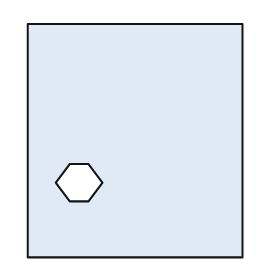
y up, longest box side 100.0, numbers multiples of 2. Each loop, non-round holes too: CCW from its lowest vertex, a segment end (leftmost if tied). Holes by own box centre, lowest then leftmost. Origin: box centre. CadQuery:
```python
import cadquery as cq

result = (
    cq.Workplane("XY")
    .moveTo(-46.0, -50.0)
    .lineTo(46.0, -50.0)
    .lineTo(46.0, 50.0)
    .lineTo(-46.0, 50.0)
    .close()
    .moveTo(-28.0, -26.0)
    .lineTo(-20.0, -26.0)
    .lineTo(-14.0, -18.0)
    .lineTo(-20.0, -10.0)
    .lineTo(-28.0, -10.0)
    .lineTo(-34.0, -18.0)
    .close()
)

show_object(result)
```